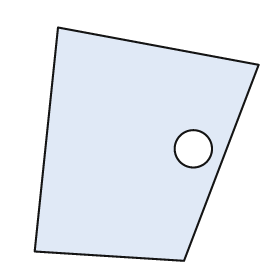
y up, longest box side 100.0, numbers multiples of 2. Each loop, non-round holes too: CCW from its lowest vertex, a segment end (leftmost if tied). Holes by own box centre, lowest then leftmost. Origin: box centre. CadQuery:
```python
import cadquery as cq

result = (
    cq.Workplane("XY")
    .moveTo(16.0, -50.0)
    .lineTo(48.0, 34.0)
    .lineTo(-38.0, 50.0)
    .lineTo(-48.0, -46.0)
    .close()
    .moveTo(20.0, -2.0)
    .circle(8.0)
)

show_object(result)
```